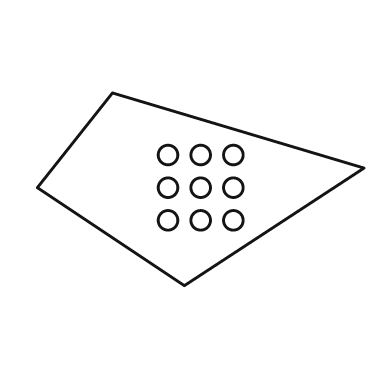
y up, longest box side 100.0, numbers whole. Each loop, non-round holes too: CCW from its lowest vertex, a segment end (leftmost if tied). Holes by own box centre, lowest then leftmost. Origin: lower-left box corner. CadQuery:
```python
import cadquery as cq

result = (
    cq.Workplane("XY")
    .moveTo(45.0, 0.0)
    .lineTo(100.0, 36.0)
    .lineTo(23.0, 59.0)
    .lineTo(0.0, 30.0)
    .close()
    .moveTo(40.0, 20.0)
    .circle(3.0)
    .moveTo(50.0, 20.0)
    .circle(3.0)
    .moveTo(60.0, 20.0)
    .circle(3.0)
    .moveTo(40.0, 30.0)
    .circle(3.0)
    .moveTo(50.0, 30.0)
    .circle(3.0)
    .moveTo(60.0, 30.0)
    .circle(3.0)
    .moveTo(40.0, 40.0)
    .circle(3.0)
    .moveTo(50.0, 40.0)
    .circle(3.0)
    .moveTo(60.0, 40.0)
    .circle(3.0)
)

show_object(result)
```